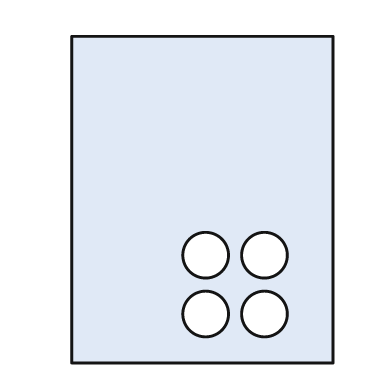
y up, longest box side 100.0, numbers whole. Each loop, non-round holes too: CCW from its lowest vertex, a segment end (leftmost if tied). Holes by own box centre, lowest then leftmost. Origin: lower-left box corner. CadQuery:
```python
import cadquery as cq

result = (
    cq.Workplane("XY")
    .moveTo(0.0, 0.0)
    .lineTo(80.0, 0.0)
    .lineTo(80.0, 100.0)
    .lineTo(0.0, 100.0)
    .close()
    .moveTo(41.0, 15.0)
    .circle(7.0)
    .moveTo(59.0, 15.0)
    .circle(7.0)
    .moveTo(41.0, 33.0)
    .circle(7.0)
    .moveTo(59.0, 33.0)
    .circle(7.0)
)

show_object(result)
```